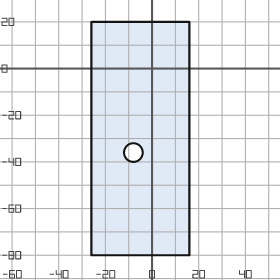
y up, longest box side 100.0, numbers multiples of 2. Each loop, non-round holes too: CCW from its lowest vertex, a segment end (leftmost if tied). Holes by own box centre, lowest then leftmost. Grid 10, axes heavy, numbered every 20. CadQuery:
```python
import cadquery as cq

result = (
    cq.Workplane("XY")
    .moveTo(-26.0, -80.0)
    .lineTo(16.0, -80.0)
    .lineTo(16.0, 20.0)
    .lineTo(-26.0, 20.0)
    .close()
    .moveTo(-8.0, -36.0)
    .circle(4.0)
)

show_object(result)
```